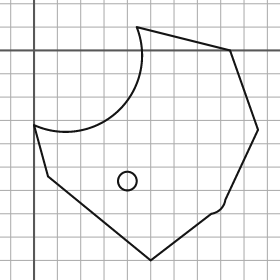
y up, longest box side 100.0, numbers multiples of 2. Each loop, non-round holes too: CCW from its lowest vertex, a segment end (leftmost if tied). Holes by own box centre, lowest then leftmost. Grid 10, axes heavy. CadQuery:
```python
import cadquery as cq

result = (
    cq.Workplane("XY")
    .moveTo(50.0, -90.0)
    .lineTo(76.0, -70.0)
    .threePointArc((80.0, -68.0), (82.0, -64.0))
    .lineTo(96.0, -34.0)
    .lineTo(84.0, 0.0)
    .lineTo(44.0, 10.0)
    .threePointArc((36.0, -26.0), (0.0, -32.0))
    .lineTo(6.0, -54.0)
    .close()
    .moveTo(40.0, -56.0)
    .circle(4.0)
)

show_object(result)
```